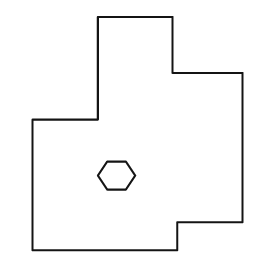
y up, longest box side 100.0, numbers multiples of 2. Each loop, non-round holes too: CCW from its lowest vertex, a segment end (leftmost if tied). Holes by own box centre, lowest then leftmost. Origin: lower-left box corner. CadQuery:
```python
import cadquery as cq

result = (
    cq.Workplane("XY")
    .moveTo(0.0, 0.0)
    .lineTo(62.0, 0.0)
    .lineTo(62.0, 12.0)
    .lineTo(90.0, 12.0)
    .lineTo(90.0, 76.0)
    .lineTo(60.0, 76.0)
    .lineTo(60.0, 100.0)
    .lineTo(28.0, 100.0)
    .lineTo(28.0, 56.0)
    .lineTo(0.0, 56.0)
    .close()
    .moveTo(32.0, 26.0)
    .lineTo(40.0, 26.0)
    .lineTo(44.0, 32.0)
    .lineTo(40.0, 38.0)
    .lineTo(32.0, 38.0)
    .lineTo(28.0, 32.0)
    .close()
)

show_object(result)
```